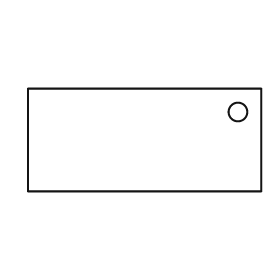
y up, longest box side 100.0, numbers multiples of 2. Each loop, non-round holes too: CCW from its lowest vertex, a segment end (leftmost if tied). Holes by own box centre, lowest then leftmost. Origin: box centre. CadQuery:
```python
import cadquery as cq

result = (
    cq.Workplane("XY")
    .moveTo(-50.0, -22.0)
    .lineTo(50.0, -22.0)
    .lineTo(50.0, 22.0)
    .lineTo(-50.0, 22.0)
    .close()
    .moveTo(40.0, 12.0)
    .circle(4.0)
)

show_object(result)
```